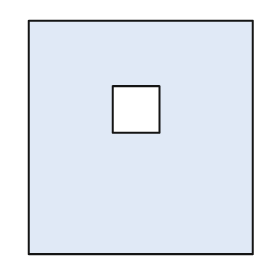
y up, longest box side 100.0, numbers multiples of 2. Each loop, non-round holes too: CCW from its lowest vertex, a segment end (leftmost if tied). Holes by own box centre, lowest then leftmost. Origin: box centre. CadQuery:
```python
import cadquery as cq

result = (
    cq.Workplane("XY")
    .moveTo(-48.0, -50.0)
    .lineTo(48.0, -50.0)
    .lineTo(48.0, 50.0)
    .lineTo(-48.0, 50.0)
    .close()
    .moveTo(-12.0, 2.0)
    .lineTo(8.0, 2.0)
    .lineTo(8.0, 22.0)
    .lineTo(-12.0, 22.0)
    .close()
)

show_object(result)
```